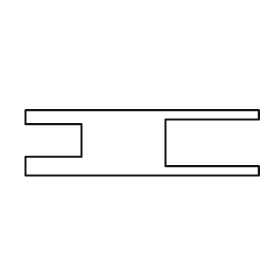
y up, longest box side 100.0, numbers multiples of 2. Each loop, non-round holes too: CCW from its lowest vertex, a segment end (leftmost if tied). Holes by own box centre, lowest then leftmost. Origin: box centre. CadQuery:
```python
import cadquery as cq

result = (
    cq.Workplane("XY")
    .moveTo(-50.0, -14.0)
    .lineTo(50.0, -14.0)
    .lineTo(50.0, -10.0)
    .lineTo(10.0, -10.0)
    .lineTo(10.0, 10.0)
    .lineTo(50.0, 10.0)
    .lineTo(50.0, 14.0)
    .lineTo(-50.0, 14.0)
    .lineTo(-50.0, 8.0)
    .lineTo(-26.0, 8.0)
    .lineTo(-26.0, -6.0)
    .lineTo(-50.0, -6.0)
    .close()
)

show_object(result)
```